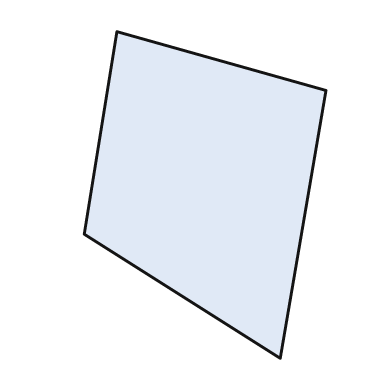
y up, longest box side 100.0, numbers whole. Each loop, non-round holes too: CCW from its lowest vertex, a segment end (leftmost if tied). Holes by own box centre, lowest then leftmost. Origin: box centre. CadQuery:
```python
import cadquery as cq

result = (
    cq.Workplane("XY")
    .moveTo(23.0, -50.0)
    .lineTo(37.0, 32.0)
    .lineTo(-27.0, 50.0)
    .lineTo(-37.0, -12.0)
    .close()
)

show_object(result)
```